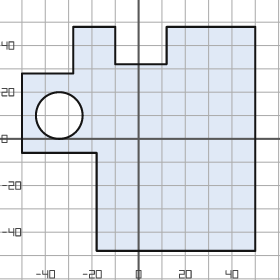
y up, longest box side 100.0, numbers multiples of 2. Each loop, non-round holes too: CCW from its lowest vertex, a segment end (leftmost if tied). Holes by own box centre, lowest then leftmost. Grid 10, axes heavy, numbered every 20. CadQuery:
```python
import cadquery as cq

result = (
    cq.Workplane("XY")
    .moveTo(-18.0, -48.0)
    .lineTo(50.0, -48.0)
    .lineTo(50.0, 48.0)
    .lineTo(12.0, 48.0)
    .lineTo(12.0, 32.0)
    .lineTo(-10.0, 32.0)
    .lineTo(-10.0, 48.0)
    .lineTo(-28.0, 48.0)
    .lineTo(-28.0, 28.0)
    .lineTo(-50.0, 28.0)
    .lineTo(-50.0, -6.0)
    .lineTo(-18.0, -6.0)
    .close()
    .moveTo(-34.0, 10.0)
    .circle(10.0)
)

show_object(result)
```